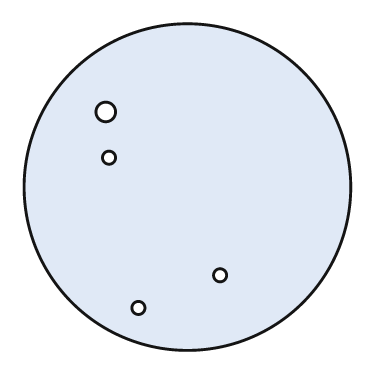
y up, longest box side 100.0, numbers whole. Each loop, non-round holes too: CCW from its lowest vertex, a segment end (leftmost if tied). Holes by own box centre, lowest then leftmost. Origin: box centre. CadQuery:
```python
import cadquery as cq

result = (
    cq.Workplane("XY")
    .moveTo(0.0, 0.0)
    .circle(50.0)
    .moveTo(-15.0, -37.0)
    .circle(2.0)
    .moveTo(10.0, -27.0)
    .circle(2.0)
    .moveTo(-24.0, 9.0)
    .circle(2.0)
    .moveTo(-25.0, 23.0)
    .circle(3.0)
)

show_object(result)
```